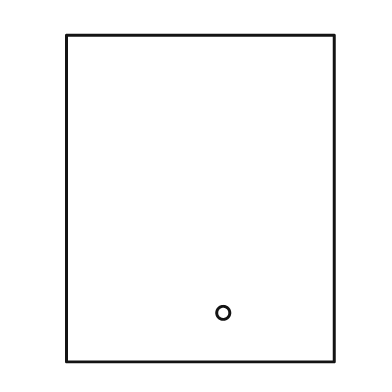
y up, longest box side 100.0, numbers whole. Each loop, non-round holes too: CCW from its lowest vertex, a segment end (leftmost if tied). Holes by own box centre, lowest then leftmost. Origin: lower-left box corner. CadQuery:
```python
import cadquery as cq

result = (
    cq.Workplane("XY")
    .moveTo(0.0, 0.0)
    .lineTo(82.0, 0.0)
    .lineTo(82.0, 100.0)
    .lineTo(0.0, 100.0)
    .close()
    .moveTo(48.0, 15.0)
    .circle(2.0)
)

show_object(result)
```